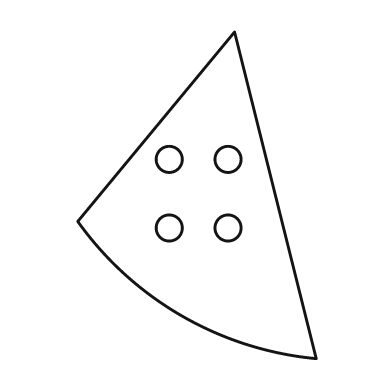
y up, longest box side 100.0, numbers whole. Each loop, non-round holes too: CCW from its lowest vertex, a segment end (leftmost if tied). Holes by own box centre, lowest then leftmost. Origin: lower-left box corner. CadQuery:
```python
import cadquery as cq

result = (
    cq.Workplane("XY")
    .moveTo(73.0, 0.0)
    .lineTo(48.0, 100.0)
    .lineTo(0.0, 42.0)
    .threePointArc((32.0, 13.0), (73.0, 0.0))
    .close()
    .moveTo(28.0, 40.0)
    .circle(4.0)
    .moveTo(46.0, 40.0)
    .circle(4.0)
    .moveTo(28.0, 61.0)
    .circle(4.0)
    .moveTo(46.0, 61.0)
    .circle(4.0)
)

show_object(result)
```